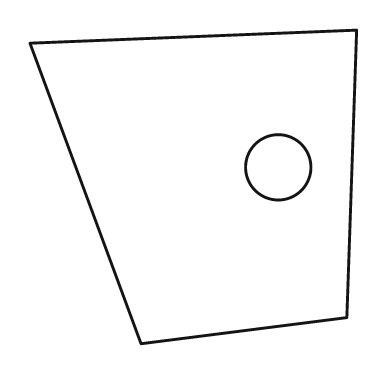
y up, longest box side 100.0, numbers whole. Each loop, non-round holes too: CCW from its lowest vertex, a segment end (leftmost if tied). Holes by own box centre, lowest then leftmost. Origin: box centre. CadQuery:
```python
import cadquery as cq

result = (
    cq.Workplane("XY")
    .moveTo(-16.0, -48.0)
    .lineTo(47.0, -40.0)
    .lineTo(50.0, 48.0)
    .lineTo(-50.0, 44.0)
    .close()
    .moveTo(26.0, 6.0)
    .circle(10.0)
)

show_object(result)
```